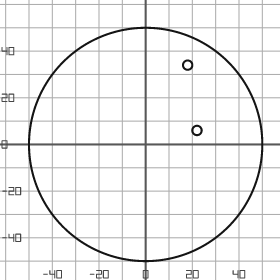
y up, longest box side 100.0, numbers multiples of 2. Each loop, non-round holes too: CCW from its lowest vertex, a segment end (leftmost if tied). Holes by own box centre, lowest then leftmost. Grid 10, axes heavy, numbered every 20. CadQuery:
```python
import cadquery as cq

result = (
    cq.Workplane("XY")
    .moveTo(0.0, 0.0)
    .circle(50.0)
    .moveTo(22.0, 6.0)
    .circle(2.0)
    .moveTo(18.0, 34.0)
    .circle(2.0)
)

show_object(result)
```